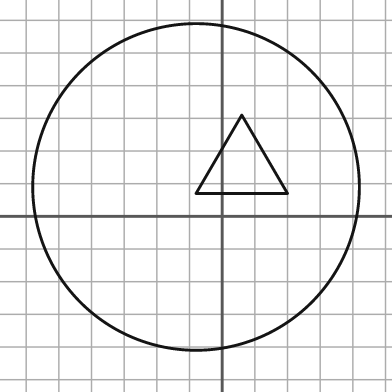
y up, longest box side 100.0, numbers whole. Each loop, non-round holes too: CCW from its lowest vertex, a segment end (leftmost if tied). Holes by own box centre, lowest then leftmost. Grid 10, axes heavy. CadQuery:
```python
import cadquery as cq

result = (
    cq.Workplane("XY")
    .moveTo(-8.0, 9.0)
    .circle(50.0)
    .moveTo(-8.0, 7.0)
    .lineTo(20.0, 7.0)
    .lineTo(6.0, 31.0)
    .close()
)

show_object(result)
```